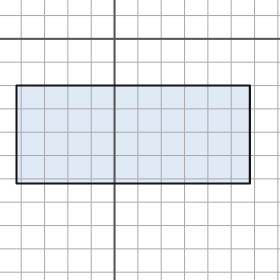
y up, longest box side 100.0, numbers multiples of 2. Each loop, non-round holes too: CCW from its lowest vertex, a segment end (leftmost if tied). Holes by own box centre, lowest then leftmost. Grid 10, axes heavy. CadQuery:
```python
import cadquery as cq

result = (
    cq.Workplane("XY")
    .moveTo(-42.0, -62.0)
    .lineTo(58.0, -62.0)
    .lineTo(58.0, -20.0)
    .lineTo(-42.0, -20.0)
    .close()
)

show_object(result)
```